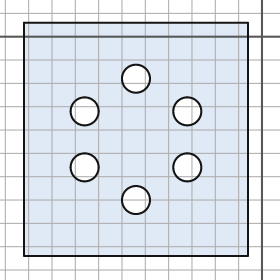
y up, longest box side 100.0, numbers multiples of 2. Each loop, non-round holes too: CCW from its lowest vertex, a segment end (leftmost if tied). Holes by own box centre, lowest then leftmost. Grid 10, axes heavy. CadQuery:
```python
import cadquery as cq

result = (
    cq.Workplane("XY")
    .moveTo(-102.0, -94.0)
    .lineTo(-6.0, -94.0)
    .lineTo(-6.0, 6.0)
    .lineTo(-102.0, 6.0)
    .close()
    .moveTo(-54.0, -70.0)
    .circle(6.0)
    .moveTo(-76.0, -56.0)
    .circle(6.0)
    .moveTo(-32.0, -56.0)
    .circle(6.0)
    .moveTo(-76.0, -32.0)
    .circle(6.0)
    .moveTo(-32.0, -32.0)
    .circle(6.0)
    .moveTo(-54.0, -18.0)
    .circle(6.0)
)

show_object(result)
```